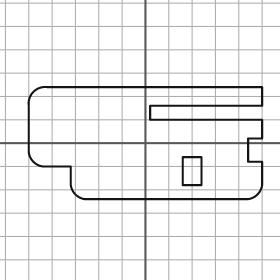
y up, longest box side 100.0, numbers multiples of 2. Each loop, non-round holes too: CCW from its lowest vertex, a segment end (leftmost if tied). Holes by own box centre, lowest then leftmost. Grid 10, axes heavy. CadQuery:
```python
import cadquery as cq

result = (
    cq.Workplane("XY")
    .moveTo(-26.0, -24.0)
    .lineTo(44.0, -24.0)
    .threePointArc((48.0, -22.0), (50.0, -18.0))
    .lineTo(50.0, -8.0)
    .lineTo(44.0, -8.0)
    .lineTo(44.0, 2.0)
    .lineTo(50.0, 2.0)
    .lineTo(50.0, 10.0)
    .lineTo(2.0, 10.0)
    .lineTo(2.0, 16.0)
    .lineTo(50.0, 16.0)
    .lineTo(50.0, 24.0)
    .lineTo(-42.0, 24.0)
    .threePointArc((-48.0, 22.0), (-50.0, 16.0))
    .lineTo(-50.0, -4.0)
    .threePointArc((-48.0, -8.0), (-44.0, -10.0))
    .lineTo(-32.0, -10.0)
    .lineTo(-32.0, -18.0)
    .threePointArc((-30.0, -22.0), (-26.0, -24.0))
    .close()
    .moveTo(16.0, -18.0)
    .lineTo(24.0, -18.0)
    .lineTo(24.0, -6.0)
    .lineTo(16.0, -6.0)
    .close()
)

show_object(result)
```